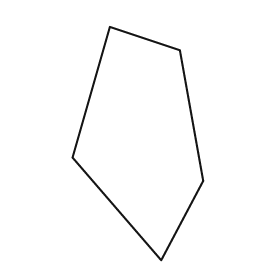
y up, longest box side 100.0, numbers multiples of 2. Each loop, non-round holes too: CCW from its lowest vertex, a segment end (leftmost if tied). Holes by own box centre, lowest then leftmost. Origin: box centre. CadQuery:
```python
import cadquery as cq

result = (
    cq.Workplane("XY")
    .moveTo(10.0, -50.0)
    .lineTo(28.0, -16.0)
    .lineTo(18.0, 40.0)
    .lineTo(-12.0, 50.0)
    .lineTo(-28.0, -6.0)
    .close()
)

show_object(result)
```